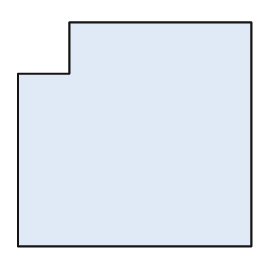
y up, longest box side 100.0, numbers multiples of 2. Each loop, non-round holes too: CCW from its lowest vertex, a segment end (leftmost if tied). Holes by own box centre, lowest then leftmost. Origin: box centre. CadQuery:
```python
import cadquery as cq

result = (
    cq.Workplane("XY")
    .moveTo(-50.0, -48.0)
    .lineTo(50.0, -48.0)
    .lineTo(50.0, 48.0)
    .lineTo(-28.0, 48.0)
    .lineTo(-28.0, 26.0)
    .lineTo(-50.0, 26.0)
    .close()
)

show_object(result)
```